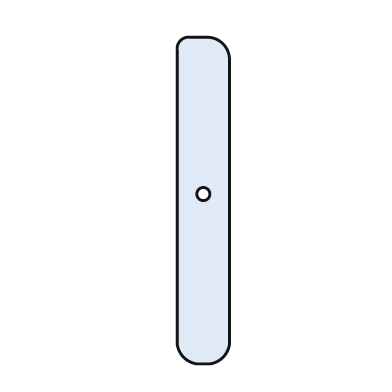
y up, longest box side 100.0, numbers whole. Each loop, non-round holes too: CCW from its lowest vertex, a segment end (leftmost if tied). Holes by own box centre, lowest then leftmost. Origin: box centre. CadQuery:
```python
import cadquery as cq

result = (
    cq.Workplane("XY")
    .moveTo(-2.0, -50.0)
    .lineTo(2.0, -50.0)
    .threePointArc((6.0, -48.0), (8.0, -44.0))
    .lineTo(8.0, 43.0)
    .threePointArc((6.0, 48.0), (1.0, 50.0))
    .lineTo(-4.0, 50.0)
    .threePointArc((-7.0, 49.0), (-8.0, 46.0))
    .lineTo(-8.0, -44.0)
    .threePointArc((-6.0, -48.0), (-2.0, -50.0))
    .close()
    .moveTo(0.0, 2.0)
    .circle(2.0)
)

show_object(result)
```